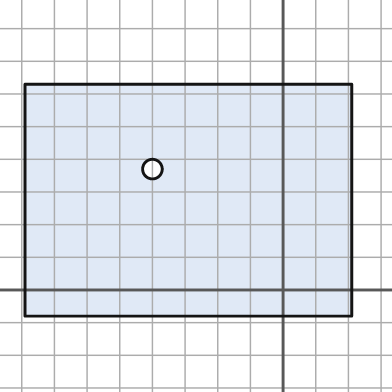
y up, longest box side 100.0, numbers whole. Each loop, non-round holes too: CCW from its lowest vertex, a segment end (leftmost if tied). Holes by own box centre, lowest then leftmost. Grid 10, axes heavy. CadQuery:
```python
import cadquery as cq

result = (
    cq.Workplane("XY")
    .moveTo(-79.0, -8.0)
    .lineTo(21.0, -8.0)
    .lineTo(21.0, 63.0)
    .lineTo(-79.0, 63.0)
    .close()
    .moveTo(-40.0, 37.0)
    .circle(3.0)
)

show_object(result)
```